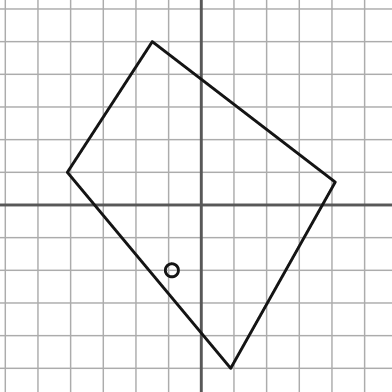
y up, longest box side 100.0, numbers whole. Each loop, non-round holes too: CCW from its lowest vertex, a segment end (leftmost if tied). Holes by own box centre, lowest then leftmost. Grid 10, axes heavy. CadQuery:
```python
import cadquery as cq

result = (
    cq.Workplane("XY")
    .moveTo(9.0, -50.0)
    .lineTo(41.0, 7.0)
    .lineTo(-15.0, 50.0)
    .lineTo(-41.0, 10.0)
    .close()
    .moveTo(-9.0, -20.0)
    .circle(2.0)
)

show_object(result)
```